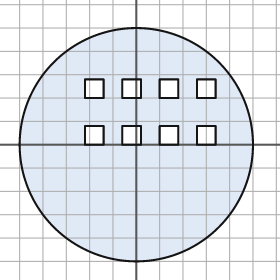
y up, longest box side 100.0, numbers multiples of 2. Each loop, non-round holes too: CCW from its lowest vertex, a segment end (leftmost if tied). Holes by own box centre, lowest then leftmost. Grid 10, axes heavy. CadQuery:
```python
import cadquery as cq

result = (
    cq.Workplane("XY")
    .moveTo(0.0, 0.0)
    .circle(50.0)
    .moveTo(-22.0, 0.0)
    .lineTo(-14.0, 0.0)
    .lineTo(-14.0, 8.0)
    .lineTo(-22.0, 8.0)
    .close()
    .moveTo(-6.0, 0.0)
    .lineTo(2.0, 0.0)
    .lineTo(2.0, 8.0)
    .lineTo(-6.0, 8.0)
    .close()
    .moveTo(10.0, 0.0)
    .lineTo(18.0, 0.0)
    .lineTo(18.0, 8.0)
    .lineTo(10.0, 8.0)
    .close()
    .moveTo(26.0, 0.0)
    .lineTo(34.0, 0.0)
    .lineTo(34.0, 8.0)
    .lineTo(26.0, 8.0)
    .close()
    .moveTo(-22.0, 20.0)
    .lineTo(-14.0, 20.0)
    .lineTo(-14.0, 28.0)
    .lineTo(-22.0, 28.0)
    .close()
    .moveTo(-6.0, 20.0)
    .lineTo(2.0, 20.0)
    .lineTo(2.0, 28.0)
    .lineTo(-6.0, 28.0)
    .close()
    .moveTo(10.0, 20.0)
    .lineTo(18.0, 20.0)
    .lineTo(18.0, 28.0)
    .lineTo(10.0, 28.0)
    .close()
    .moveTo(26.0, 20.0)
    .lineTo(34.0, 20.0)
    .lineTo(34.0, 28.0)
    .lineTo(26.0, 28.0)
    .close()
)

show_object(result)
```